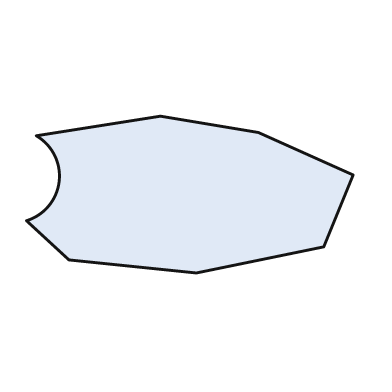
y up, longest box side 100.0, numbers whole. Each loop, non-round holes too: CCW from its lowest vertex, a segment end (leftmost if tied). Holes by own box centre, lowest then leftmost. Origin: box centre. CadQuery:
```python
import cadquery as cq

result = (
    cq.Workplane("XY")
    .moveTo(2.0, -24.0)
    .lineTo(41.0, -16.0)
    .lineTo(50.0, 6.0)
    .lineTo(21.0, 19.0)
    .lineTo(-9.0, 24.0)
    .lineTo(-47.0, 18.0)
    .threePointArc((-40.0, 4.0), (-50.0, -8.0))
    .lineTo(-37.0, -20.0)
    .close()
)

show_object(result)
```